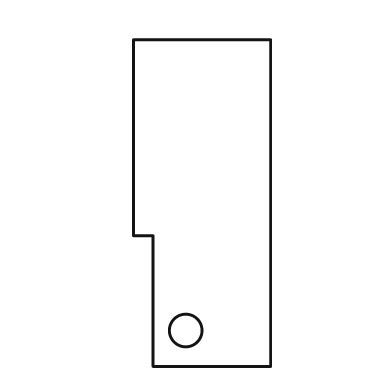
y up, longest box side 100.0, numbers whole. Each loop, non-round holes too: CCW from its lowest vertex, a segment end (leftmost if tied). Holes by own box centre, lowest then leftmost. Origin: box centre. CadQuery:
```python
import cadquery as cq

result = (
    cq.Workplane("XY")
    .moveTo(-15.0, -50.0)
    .lineTo(21.0, -50.0)
    .lineTo(21.0, 50.0)
    .lineTo(-21.0, 50.0)
    .lineTo(-21.0, -10.0)
    .lineTo(-15.0, -10.0)
    .close()
    .moveTo(-5.0, -39.0)
    .circle(5.0)
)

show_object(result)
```